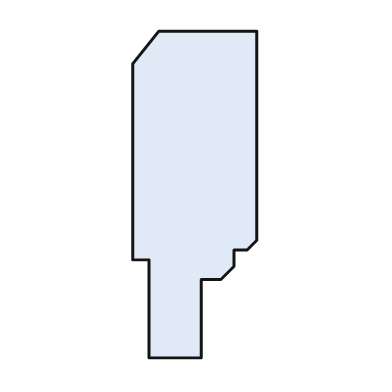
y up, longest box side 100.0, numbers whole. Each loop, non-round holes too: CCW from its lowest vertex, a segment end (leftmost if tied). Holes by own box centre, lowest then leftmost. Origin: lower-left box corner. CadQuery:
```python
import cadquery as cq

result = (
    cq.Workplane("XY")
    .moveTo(5.0, 0.0)
    .lineTo(21.0, 0.0)
    .lineTo(21.0, 24.0)
    .lineTo(27.0, 24.0)
    .lineTo(31.0, 28.0)
    .lineTo(31.0, 33.0)
    .lineTo(35.0, 33.0)
    .lineTo(38.0, 36.0)
    .lineTo(38.0, 100.0)
    .lineTo(8.0, 100.0)
    .lineTo(0.0, 90.0)
    .lineTo(0.0, 30.0)
    .lineTo(5.0, 30.0)
    .close()
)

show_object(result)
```